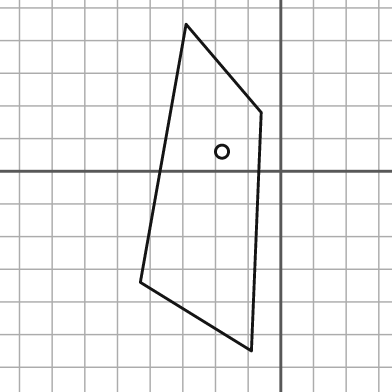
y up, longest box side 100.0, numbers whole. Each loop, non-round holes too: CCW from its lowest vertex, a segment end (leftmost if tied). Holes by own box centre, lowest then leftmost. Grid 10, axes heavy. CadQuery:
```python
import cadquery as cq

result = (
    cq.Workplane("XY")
    .moveTo(-9.0, -55.0)
    .lineTo(-6.0, 18.0)
    .lineTo(-29.0, 45.0)
    .lineTo(-43.0, -34.0)
    .close()
    .moveTo(-18.0, 6.0)
    .circle(2.0)
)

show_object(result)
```